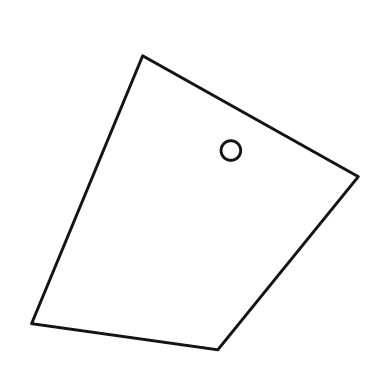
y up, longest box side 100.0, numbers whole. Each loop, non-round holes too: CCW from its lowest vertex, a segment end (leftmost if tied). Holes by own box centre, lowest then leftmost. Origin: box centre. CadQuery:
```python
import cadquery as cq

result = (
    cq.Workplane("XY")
    .moveTo(7.0, -45.0)
    .lineTo(50.0, 8.0)
    .lineTo(-16.0, 45.0)
    .lineTo(-50.0, -37.0)
    .close()
    .moveTo(11.0, 16.0)
    .circle(3.0)
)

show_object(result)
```